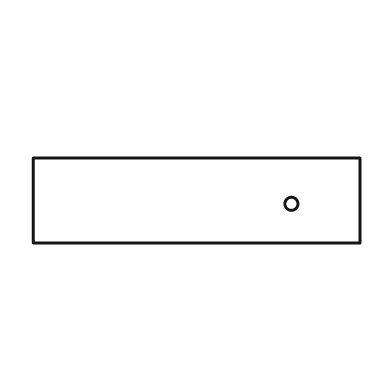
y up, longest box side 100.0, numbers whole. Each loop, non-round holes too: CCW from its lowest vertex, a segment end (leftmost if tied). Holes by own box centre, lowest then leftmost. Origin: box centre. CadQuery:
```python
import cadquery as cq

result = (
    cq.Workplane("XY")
    .moveTo(-50.0, -13.0)
    .lineTo(50.0, -13.0)
    .lineTo(50.0, 13.0)
    .lineTo(-50.0, 13.0)
    .close()
    .moveTo(29.0, -1.0)
    .circle(2.0)
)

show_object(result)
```